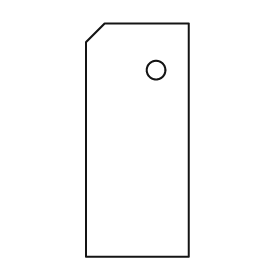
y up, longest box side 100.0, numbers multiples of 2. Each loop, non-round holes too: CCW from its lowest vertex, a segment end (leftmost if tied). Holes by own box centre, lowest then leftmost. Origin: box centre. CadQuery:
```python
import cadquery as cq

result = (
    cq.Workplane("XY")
    .moveTo(-22.0, -50.0)
    .lineTo(22.0, -50.0)
    .lineTo(22.0, 50.0)
    .lineTo(-14.0, 50.0)
    .lineTo(-22.0, 42.0)
    .close()
    .moveTo(8.0, 30.0)
    .circle(4.0)
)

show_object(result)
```